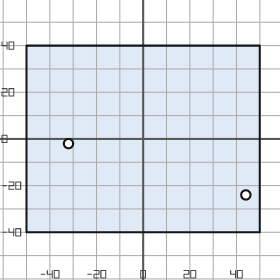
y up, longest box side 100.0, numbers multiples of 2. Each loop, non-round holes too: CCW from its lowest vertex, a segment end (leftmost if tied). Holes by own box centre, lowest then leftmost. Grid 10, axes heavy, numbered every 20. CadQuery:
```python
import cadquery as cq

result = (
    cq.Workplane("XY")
    .moveTo(-50.0, -40.0)
    .lineTo(50.0, -40.0)
    .lineTo(50.0, 40.0)
    .lineTo(-50.0, 40.0)
    .close()
    .moveTo(44.0, -24.0)
    .circle(2.0)
    .moveTo(-32.0, -2.0)
    .circle(2.0)
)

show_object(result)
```